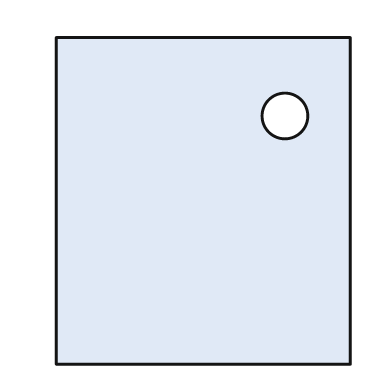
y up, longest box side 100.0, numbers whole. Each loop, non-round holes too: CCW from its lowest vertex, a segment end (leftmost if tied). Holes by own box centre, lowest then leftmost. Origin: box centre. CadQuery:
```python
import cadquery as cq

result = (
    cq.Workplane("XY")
    .moveTo(-45.0, -50.0)
    .lineTo(45.0, -50.0)
    .lineTo(45.0, 50.0)
    .lineTo(-45.0, 50.0)
    .close()
    .moveTo(25.0, 26.0)
    .circle(7.0)
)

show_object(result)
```